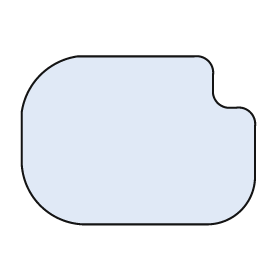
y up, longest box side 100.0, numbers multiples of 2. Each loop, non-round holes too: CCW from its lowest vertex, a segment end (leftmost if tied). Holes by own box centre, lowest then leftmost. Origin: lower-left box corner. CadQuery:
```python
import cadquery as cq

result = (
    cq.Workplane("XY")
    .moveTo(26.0, 0.0)
    .lineTo(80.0, 0.0)
    .threePointArc((94.0, 6.0), (100.0, 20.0))
    .lineTo(100.0, 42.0)
    .threePointArc((98.0, 48.0), (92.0, 50.0))
    .lineTo(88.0, 50.0)
    .threePointArc((84.0, 52.0), (82.0, 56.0))
    .lineTo(82.0, 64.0)
    .threePointArc((80.0, 70.0), (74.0, 72.0))
    .lineTo(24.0, 72.0)
    .threePointArc((8.0, 64.0), (0.0, 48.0))
    .lineTo(0.0, 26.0)
    .threePointArc((8.0, 8.0), (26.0, 0.0))
    .close()
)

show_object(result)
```